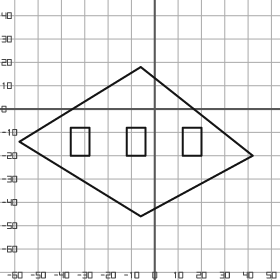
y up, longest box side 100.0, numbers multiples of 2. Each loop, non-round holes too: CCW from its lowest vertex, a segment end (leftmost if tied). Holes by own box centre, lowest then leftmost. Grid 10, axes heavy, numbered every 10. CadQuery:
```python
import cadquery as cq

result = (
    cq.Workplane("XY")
    .moveTo(-6.0, -46.0)
    .lineTo(42.0, -20.0)
    .lineTo(-6.0, 18.0)
    .lineTo(-58.0, -14.0)
    .close()
    .moveTo(-36.0, -20.0)
    .lineTo(-28.0, -20.0)
    .lineTo(-28.0, -8.0)
    .lineTo(-36.0, -8.0)
    .close()
    .moveTo(-12.0, -20.0)
    .lineTo(-4.0, -20.0)
    .lineTo(-4.0, -8.0)
    .lineTo(-12.0, -8.0)
    .close()
    .moveTo(12.0, -20.0)
    .lineTo(20.0, -20.0)
    .lineTo(20.0, -8.0)
    .lineTo(12.0, -8.0)
    .close()
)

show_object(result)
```